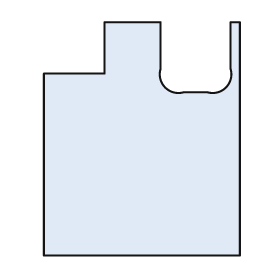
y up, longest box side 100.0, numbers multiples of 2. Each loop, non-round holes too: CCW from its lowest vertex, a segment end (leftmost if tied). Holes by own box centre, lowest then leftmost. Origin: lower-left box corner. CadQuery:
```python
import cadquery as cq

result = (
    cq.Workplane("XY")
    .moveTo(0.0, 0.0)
    .lineTo(84.0, 0.0)
    .lineTo(84.0, 100.0)
    .lineTo(80.0, 100.0)
    .lineTo(80.0, 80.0)
    .threePointArc((78.0, 72.0), (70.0, 70.0))
    .lineTo(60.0, 70.0)
    .threePointArc((52.0, 72.0), (50.0, 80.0))
    .lineTo(50.0, 100.0)
    .lineTo(26.0, 100.0)
    .lineTo(26.0, 78.0)
    .lineTo(0.0, 78.0)
    .close()
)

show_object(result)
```